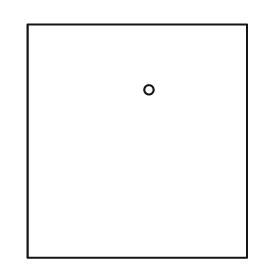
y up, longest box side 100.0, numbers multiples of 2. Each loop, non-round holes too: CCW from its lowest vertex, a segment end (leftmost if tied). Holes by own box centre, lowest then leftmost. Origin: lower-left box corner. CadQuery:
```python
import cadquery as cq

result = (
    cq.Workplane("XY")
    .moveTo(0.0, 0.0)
    .lineTo(94.0, 0.0)
    .lineTo(94.0, 100.0)
    .lineTo(0.0, 100.0)
    .close()
    .moveTo(52.0, 72.0)
    .circle(2.0)
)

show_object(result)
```